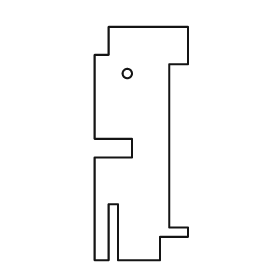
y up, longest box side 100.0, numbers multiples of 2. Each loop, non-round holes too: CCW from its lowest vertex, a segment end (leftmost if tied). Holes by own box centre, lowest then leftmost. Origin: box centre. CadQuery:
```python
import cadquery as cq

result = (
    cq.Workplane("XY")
    .moveTo(-20.0, -50.0)
    .lineTo(-14.0, -50.0)
    .lineTo(-14.0, -26.0)
    .lineTo(-10.0, -26.0)
    .lineTo(-10.0, -50.0)
    .lineTo(8.0, -50.0)
    .lineTo(8.0, -40.0)
    .lineTo(20.0, -40.0)
    .lineTo(20.0, -36.0)
    .lineTo(12.0, -36.0)
    .lineTo(12.0, 34.0)
    .lineTo(20.0, 34.0)
    .lineTo(20.0, 50.0)
    .lineTo(-14.0, 50.0)
    .lineTo(-14.0, 38.0)
    .lineTo(-20.0, 38.0)
    .lineTo(-20.0, 2.0)
    .lineTo(-4.0, 2.0)
    .lineTo(-4.0, -6.0)
    .lineTo(-20.0, -6.0)
    .close()
    .moveTo(-6.0, 30.0)
    .circle(2.0)
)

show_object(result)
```